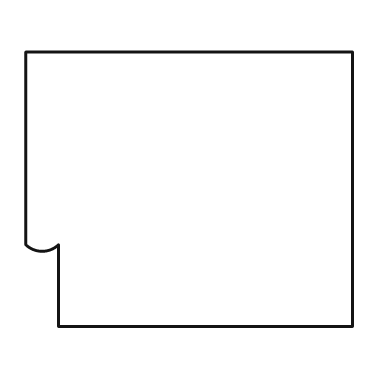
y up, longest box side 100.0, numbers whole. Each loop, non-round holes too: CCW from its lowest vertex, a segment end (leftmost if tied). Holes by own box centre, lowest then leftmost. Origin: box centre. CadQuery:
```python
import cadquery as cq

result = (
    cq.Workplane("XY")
    .moveTo(-40.0, -42.0)
    .lineTo(50.0, -42.0)
    .lineTo(50.0, 42.0)
    .lineTo(-50.0, 42.0)
    .lineTo(-50.0, -17.0)
    .threePointArc((-45.0, -19.0), (-40.0, -17.0))
    .close()
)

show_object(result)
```